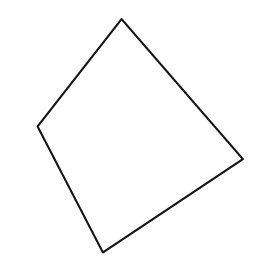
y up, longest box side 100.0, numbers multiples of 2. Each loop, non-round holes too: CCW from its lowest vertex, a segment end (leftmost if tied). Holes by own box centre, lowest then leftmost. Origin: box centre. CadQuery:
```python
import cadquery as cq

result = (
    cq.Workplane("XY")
    .moveTo(-16.0, -50.0)
    .lineTo(44.0, -10.0)
    .lineTo(-8.0, 50.0)
    .lineTo(-44.0, 4.0)
    .close()
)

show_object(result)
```